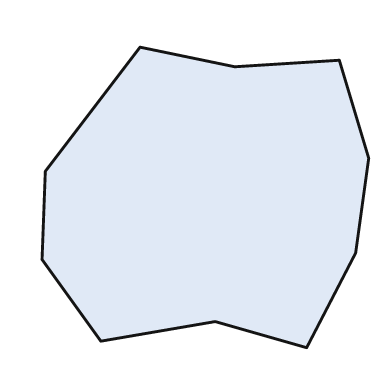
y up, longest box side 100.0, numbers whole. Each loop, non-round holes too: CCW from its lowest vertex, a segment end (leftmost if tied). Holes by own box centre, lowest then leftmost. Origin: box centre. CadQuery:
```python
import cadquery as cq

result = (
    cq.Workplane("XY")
    .moveTo(31.0, -46.0)
    .lineTo(46.0, -17.0)
    .lineTo(50.0, 12.0)
    .lineTo(41.0, 42.0)
    .lineTo(9.0, 40.0)
    .lineTo(-20.0, 46.0)
    .lineTo(-49.0, 8.0)
    .lineTo(-50.0, -19.0)
    .lineTo(-32.0, -44.0)
    .lineTo(3.0, -38.0)
    .close()
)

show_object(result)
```